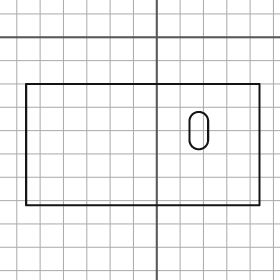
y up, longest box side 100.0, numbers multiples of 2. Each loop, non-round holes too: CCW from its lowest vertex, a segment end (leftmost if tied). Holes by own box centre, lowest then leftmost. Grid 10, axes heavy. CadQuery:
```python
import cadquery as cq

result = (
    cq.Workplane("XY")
    .moveTo(-56.0, -72.0)
    .lineTo(44.0, -72.0)
    .lineTo(44.0, -20.0)
    .lineTo(-56.0, -20.0)
    .close()
    .moveTo(14.0, -44.0)
    .threePointArc((18.0, -48.0), (22.0, -44.0))
    .lineTo(22.0, -36.0)
    .threePointArc((18.0, -32.0), (14.0, -36.0))
    .close()
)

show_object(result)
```